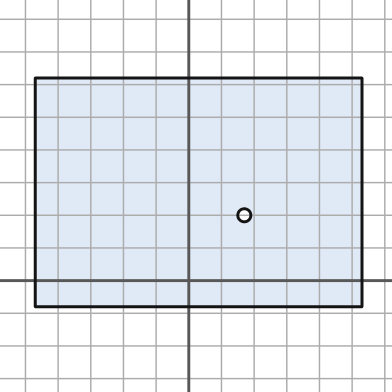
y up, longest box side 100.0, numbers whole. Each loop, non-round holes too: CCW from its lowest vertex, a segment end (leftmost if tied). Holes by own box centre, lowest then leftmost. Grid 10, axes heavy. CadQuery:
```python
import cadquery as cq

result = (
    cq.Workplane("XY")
    .moveTo(-47.0, -8.0)
    .lineTo(53.0, -8.0)
    .lineTo(53.0, 62.0)
    .lineTo(-47.0, 62.0)
    .close()
    .moveTo(17.0, 20.0)
    .circle(2.0)
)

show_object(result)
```